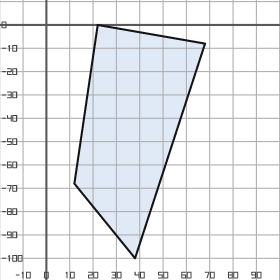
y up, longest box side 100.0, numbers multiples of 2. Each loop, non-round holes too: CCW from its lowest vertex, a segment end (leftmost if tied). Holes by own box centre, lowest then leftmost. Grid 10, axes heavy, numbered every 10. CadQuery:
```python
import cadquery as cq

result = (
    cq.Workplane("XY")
    .moveTo(38.0, -100.0)
    .lineTo(68.0, -8.0)
    .lineTo(22.0, 0.0)
    .lineTo(12.0, -68.0)
    .close()
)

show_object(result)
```